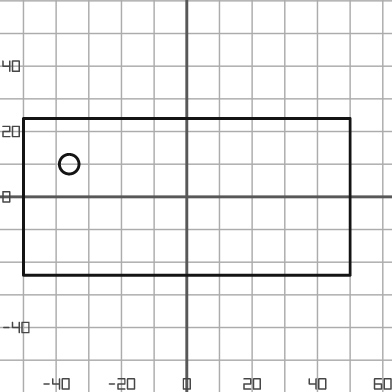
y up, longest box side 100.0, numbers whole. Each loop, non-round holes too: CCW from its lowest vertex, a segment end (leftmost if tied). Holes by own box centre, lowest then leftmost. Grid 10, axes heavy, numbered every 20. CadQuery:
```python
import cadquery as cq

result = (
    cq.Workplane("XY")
    .moveTo(-50.0, -24.0)
    .lineTo(50.0, -24.0)
    .lineTo(50.0, 24.0)
    .lineTo(-50.0, 24.0)
    .close()
    .moveTo(-36.0, 10.0)
    .circle(3.0)
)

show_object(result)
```